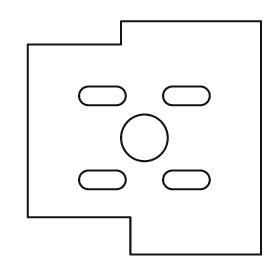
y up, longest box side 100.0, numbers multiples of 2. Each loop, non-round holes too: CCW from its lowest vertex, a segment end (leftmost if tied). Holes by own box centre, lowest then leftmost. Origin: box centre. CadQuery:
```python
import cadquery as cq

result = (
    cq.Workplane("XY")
    .moveTo(-6.0, -50.0)
    .lineTo(50.0, -50.0)
    .lineTo(50.0, 50.0)
    .lineTo(-10.0, 50.0)
    .lineTo(-10.0, 40.0)
    .lineTo(-50.0, 40.0)
    .lineTo(-50.0, -34.0)
    .lineTo(-6.0, -34.0)
    .close()
    .moveTo(-24.0, -22.0)
    .lineTo(-12.0, -22.0)
    .threePointArc((-8.0, -18.0), (-12.0, -14.0))
    .lineTo(-24.0, -14.0)
    .threePointArc((-28.0, -18.0), (-24.0, -22.0))
    .close()
    .moveTo(12.0, -22.0)
    .lineTo(24.0, -22.0)
    .threePointArc((28.0, -18.0), (24.0, -14.0))
    .lineTo(12.0, -14.0)
    .threePointArc((8.0, -18.0), (12.0, -22.0))
    .close()
    .moveTo(0.0, 0.0)
    .circle(10.0)
    .moveTo(-24.0, 14.0)
    .lineTo(-12.0, 14.0)
    .threePointArc((-8.0, 18.0), (-12.0, 22.0))
    .lineTo(-24.0, 22.0)
    .threePointArc((-28.0, 18.0), (-24.0, 14.0))
    .close()
    .moveTo(12.0, 14.0)
    .lineTo(24.0, 14.0)
    .threePointArc((28.0, 18.0), (24.0, 22.0))
    .lineTo(12.0, 22.0)
    .threePointArc((8.0, 18.0), (12.0, 14.0))
    .close()
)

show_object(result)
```